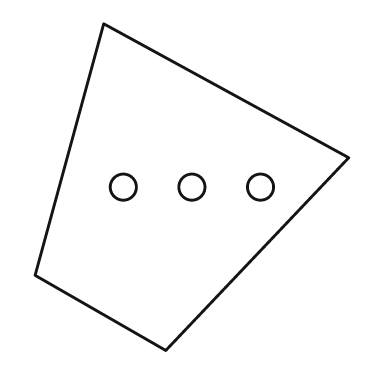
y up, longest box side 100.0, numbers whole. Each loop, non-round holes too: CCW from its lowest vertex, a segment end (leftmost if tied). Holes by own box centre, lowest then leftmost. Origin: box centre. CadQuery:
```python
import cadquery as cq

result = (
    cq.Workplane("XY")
    .moveTo(-8.0, -50.0)
    .lineTo(48.0, 9.0)
    .lineTo(-27.0, 50.0)
    .lineTo(-48.0, -27.0)
    .close()
    .moveTo(-21.0, 0.0)
    .circle(4.0)
    .moveTo(0.0, 0.0)
    .circle(4.0)
    .moveTo(21.0, 0.0)
    .circle(4.0)
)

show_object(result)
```